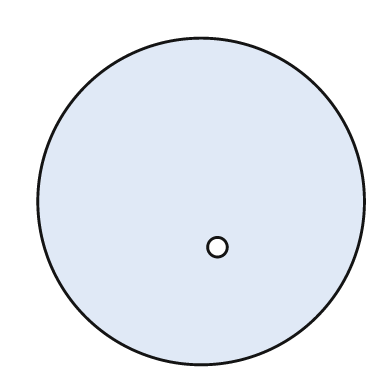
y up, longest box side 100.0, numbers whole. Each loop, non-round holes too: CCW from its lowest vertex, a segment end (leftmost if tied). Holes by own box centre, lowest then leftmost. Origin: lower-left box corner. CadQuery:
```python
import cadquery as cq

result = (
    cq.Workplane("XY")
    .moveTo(50.0, 50.0)
    .circle(50.0)
    .moveTo(55.0, 36.0)
    .circle(3.0)
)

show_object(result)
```